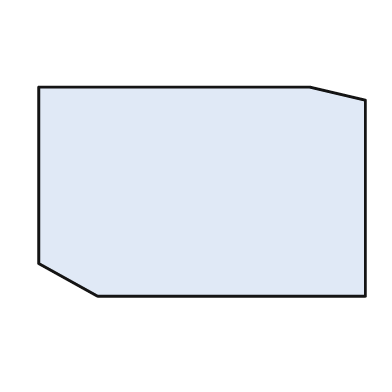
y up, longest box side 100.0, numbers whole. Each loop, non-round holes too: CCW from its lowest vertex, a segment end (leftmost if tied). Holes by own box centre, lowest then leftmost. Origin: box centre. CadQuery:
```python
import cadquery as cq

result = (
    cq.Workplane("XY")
    .moveTo(-32.0, -32.0)
    .lineTo(50.0, -32.0)
    .lineTo(50.0, 28.0)
    .lineTo(33.0, 32.0)
    .lineTo(-50.0, 32.0)
    .lineTo(-50.0, -22.0)
    .close()
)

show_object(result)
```